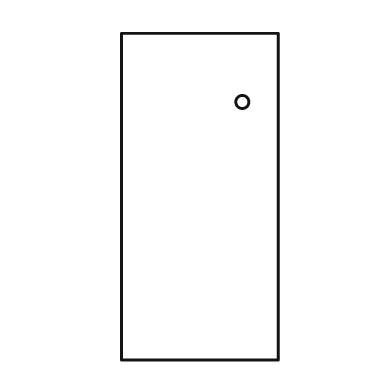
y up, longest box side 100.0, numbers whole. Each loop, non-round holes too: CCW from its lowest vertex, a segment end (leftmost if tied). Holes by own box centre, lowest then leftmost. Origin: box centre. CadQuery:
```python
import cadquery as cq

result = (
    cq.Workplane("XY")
    .moveTo(-24.0, -50.0)
    .lineTo(24.0, -50.0)
    .lineTo(24.0, 50.0)
    .lineTo(-24.0, 50.0)
    .close()
    .moveTo(13.0, 29.0)
    .circle(2.0)
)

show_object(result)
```